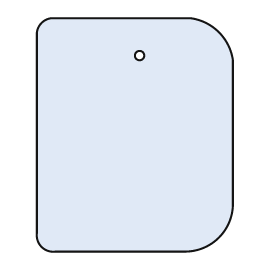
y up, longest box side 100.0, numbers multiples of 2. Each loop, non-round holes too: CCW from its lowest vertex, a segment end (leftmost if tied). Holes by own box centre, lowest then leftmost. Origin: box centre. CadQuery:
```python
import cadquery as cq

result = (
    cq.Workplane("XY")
    .moveTo(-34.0, -50.0)
    .lineTo(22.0, -50.0)
    .threePointArc((36.0, -44.0), (42.0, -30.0))
    .lineTo(42.0, 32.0)
    .threePointArc((36.0, 44.0), (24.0, 50.0))
    .lineTo(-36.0, 50.0)
    .threePointArc((-40.0, 48.0), (-42.0, 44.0))
    .lineTo(-42.0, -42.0)
    .threePointArc((-40.0, -48.0), (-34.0, -50.0))
    .close()
    .moveTo(2.0, 34.0)
    .circle(2.0)
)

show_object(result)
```